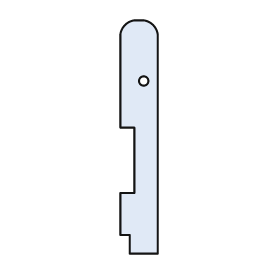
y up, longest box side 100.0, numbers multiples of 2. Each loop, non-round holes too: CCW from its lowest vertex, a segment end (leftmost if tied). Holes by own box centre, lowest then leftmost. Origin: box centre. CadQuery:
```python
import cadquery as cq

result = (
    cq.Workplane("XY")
    .moveTo(-4.0, -50.0)
    .lineTo(8.0, -50.0)
    .lineTo(8.0, 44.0)
    .threePointArc((6.0, 48.0), (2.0, 50.0))
    .lineTo(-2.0, 50.0)
    .threePointArc((-6.0, 48.0), (-8.0, 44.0))
    .lineTo(-8.0, 4.0)
    .lineTo(-2.0, 4.0)
    .lineTo(-2.0, -24.0)
    .lineTo(-8.0, -24.0)
    .lineTo(-8.0, -42.0)
    .lineTo(-4.0, -42.0)
    .close()
    .moveTo(2.0, 24.0)
    .circle(2.0)
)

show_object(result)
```